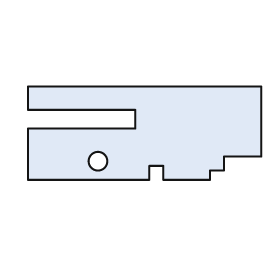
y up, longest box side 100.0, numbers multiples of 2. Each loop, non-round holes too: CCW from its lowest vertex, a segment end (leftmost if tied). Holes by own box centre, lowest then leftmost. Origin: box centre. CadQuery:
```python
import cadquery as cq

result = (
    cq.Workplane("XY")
    .moveTo(-50.0, -20.0)
    .lineTo(2.0, -20.0)
    .lineTo(2.0, -14.0)
    .lineTo(8.0, -14.0)
    .lineTo(8.0, -20.0)
    .lineTo(28.0, -20.0)
    .lineTo(28.0, -16.0)
    .lineTo(34.0, -16.0)
    .lineTo(34.0, -10.0)
    .lineTo(50.0, -10.0)
    .lineTo(50.0, 20.0)
    .lineTo(-50.0, 20.0)
    .lineTo(-50.0, 10.0)
    .lineTo(-4.0, 10.0)
    .lineTo(-4.0, 2.0)
    .lineTo(-50.0, 2.0)
    .close()
    .moveTo(-20.0, -12.0)
    .circle(4.0)
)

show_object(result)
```